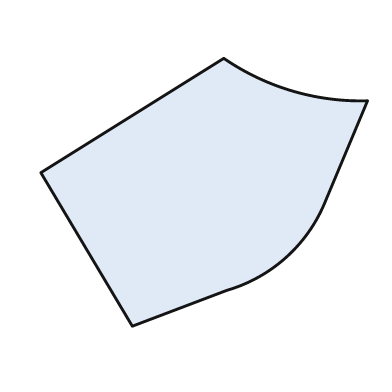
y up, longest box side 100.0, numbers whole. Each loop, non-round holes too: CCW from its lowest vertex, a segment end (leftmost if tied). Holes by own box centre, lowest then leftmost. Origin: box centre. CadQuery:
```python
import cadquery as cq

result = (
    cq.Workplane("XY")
    .moveTo(-22.0, -41.0)
    .lineTo(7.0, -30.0)
    .threePointArc((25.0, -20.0), (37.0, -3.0))
    .lineTo(50.0, 28.0)
    .threePointArc((27.0, 31.0), (6.0, 41.0))
    .lineTo(-50.0, 6.0)
    .close()
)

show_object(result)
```